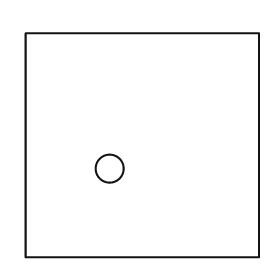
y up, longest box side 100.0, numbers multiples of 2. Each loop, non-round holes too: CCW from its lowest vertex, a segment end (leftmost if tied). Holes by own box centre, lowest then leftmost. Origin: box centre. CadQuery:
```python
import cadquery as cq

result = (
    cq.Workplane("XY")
    .moveTo(-50.0, -48.0)
    .lineTo(50.0, -48.0)
    .lineTo(50.0, 48.0)
    .lineTo(-50.0, 48.0)
    .close()
    .moveTo(-14.0, -10.0)
    .circle(6.0)
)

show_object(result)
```